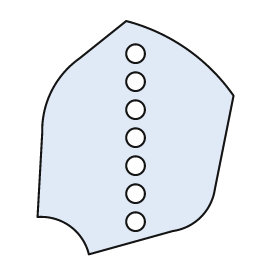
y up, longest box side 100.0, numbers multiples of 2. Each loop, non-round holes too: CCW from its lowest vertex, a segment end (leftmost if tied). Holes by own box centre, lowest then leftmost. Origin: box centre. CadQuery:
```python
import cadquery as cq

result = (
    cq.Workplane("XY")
    .moveTo(-20.0, -50.0)
    .lineTo(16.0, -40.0)
    .threePointArc((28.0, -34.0), (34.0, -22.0))
    .lineTo(42.0, 18.0)
    .threePointArc((22.0, 38.0), (-4.0, 50.0))
    .lineTo(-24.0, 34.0)
    .threePointArc((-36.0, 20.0), (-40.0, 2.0))
    .lineTo(-42.0, -34.0)
    .threePointArc((-28.0, -38.0), (-20.0, -50.0))
    .close()
    .moveTo(0.0, -36.0)
    .circle(4.0)
    .moveTo(0.0, -24.0)
    .circle(4.0)
    .moveTo(0.0, -12.0)
    .circle(4.0)
    .moveTo(0.0, 0.0)
    .circle(4.0)
    .moveTo(0.0, 12.0)
    .circle(4.0)
    .moveTo(0.0, 24.0)
    .circle(4.0)
    .moveTo(0.0, 36.0)
    .circle(4.0)
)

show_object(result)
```